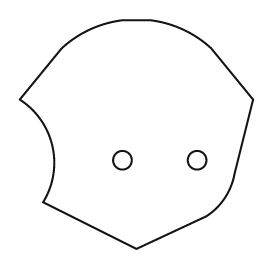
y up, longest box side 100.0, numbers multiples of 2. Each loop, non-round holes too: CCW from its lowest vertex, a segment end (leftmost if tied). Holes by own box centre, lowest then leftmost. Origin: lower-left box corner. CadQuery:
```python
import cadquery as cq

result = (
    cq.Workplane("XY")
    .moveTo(50.0, 0.0)
    .lineTo(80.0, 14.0)
    .threePointArc((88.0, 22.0), (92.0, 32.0))
    .lineTo(100.0, 64.0)
    .lineTo(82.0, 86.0)
    .threePointArc((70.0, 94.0), (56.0, 98.0))
    .lineTo(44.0, 98.0)
    .threePointArc((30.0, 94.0), (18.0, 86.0))
    .lineTo(0.0, 64.0)
    .threePointArc((14.0, 44.0), (10.0, 20.0))
    .close()
    .moveTo(44.0, 38.0)
    .circle(4.0)
    .moveTo(76.0, 38.0)
    .circle(4.0)
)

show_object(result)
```